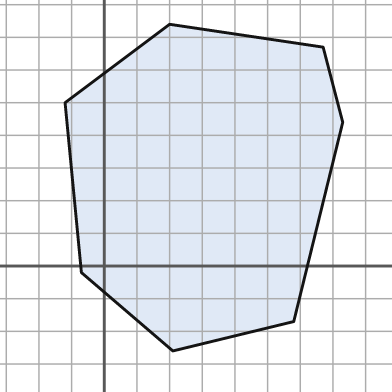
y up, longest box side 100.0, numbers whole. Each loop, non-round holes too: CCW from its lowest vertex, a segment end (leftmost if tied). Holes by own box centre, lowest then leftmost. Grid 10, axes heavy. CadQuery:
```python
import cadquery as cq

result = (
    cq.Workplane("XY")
    .moveTo(21.0, -26.0)
    .lineTo(58.0, -17.0)
    .lineTo(73.0, 44.0)
    .lineTo(67.0, 67.0)
    .lineTo(20.0, 74.0)
    .lineTo(-12.0, 50.0)
    .lineTo(-7.0, -2.0)
    .close()
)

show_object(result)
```